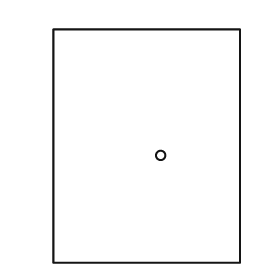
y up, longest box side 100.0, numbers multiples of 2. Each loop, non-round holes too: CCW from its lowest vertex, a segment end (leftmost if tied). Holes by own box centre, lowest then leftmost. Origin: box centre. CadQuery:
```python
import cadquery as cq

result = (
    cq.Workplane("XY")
    .moveTo(-40.0, -50.0)
    .lineTo(40.0, -50.0)
    .lineTo(40.0, 50.0)
    .lineTo(-40.0, 50.0)
    .close()
    .moveTo(6.0, -4.0)
    .circle(2.0)
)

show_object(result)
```